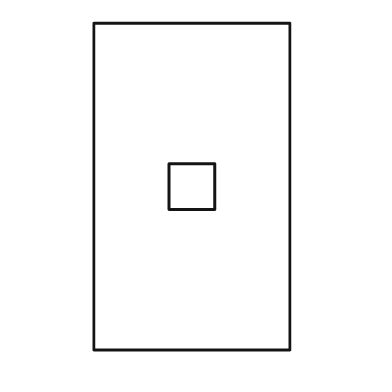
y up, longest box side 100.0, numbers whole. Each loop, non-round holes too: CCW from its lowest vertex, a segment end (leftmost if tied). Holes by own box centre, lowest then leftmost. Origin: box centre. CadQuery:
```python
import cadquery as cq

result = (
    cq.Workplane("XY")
    .moveTo(-30.0, -50.0)
    .lineTo(30.0, -50.0)
    .lineTo(30.0, 50.0)
    .lineTo(-30.0, 50.0)
    .close()
    .moveTo(-7.0, -7.0)
    .lineTo(7.0, -7.0)
    .lineTo(7.0, 7.0)
    .lineTo(-7.0, 7.0)
    .close()
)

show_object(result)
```